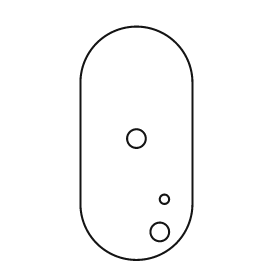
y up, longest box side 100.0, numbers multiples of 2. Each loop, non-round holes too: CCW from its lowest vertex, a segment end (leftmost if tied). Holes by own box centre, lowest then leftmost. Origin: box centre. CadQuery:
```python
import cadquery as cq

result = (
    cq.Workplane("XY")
    .moveTo(-24.0, -26.0)
    .threePointArc((0.0, -50.0), (24.0, -26.0))
    .lineTo(24.0, 26.0)
    .threePointArc((0.0, 50.0), (-24.0, 26.0))
    .close()
    .moveTo(10.0, -38.0)
    .circle(4.0)
    .moveTo(12.0, -24.0)
    .circle(2.0)
    .moveTo(0.0, 2.0)
    .circle(4.0)
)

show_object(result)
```